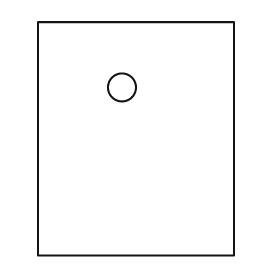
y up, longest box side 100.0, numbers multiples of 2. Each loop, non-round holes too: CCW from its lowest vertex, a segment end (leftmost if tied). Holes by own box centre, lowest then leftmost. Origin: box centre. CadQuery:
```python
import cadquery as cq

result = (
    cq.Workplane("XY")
    .moveTo(-42.0, -50.0)
    .lineTo(42.0, -50.0)
    .lineTo(42.0, 50.0)
    .lineTo(-42.0, 50.0)
    .close()
    .moveTo(-6.0, 22.0)
    .circle(6.0)
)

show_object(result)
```